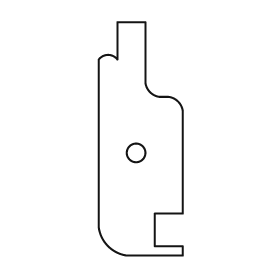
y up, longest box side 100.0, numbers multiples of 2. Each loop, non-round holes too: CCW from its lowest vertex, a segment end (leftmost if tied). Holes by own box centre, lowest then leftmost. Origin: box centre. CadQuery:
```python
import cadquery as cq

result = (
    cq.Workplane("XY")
    .moveTo(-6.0, -50.0)
    .lineTo(18.0, -50.0)
    .lineTo(18.0, -46.0)
    .lineTo(6.0, -46.0)
    .lineTo(6.0, -32.0)
    .lineTo(18.0, -32.0)
    .lineTo(18.0, 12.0)
    .threePointArc((16.0, 16.0), (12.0, 18.0))
    .lineTo(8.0, 18.0)
    .threePointArc((4.0, 20.0), (2.0, 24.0))
    .lineTo(2.0, 50.0)
    .lineTo(-10.0, 50.0)
    .lineTo(-10.0, 34.0)
    .threePointArc((-14.0, 36.0), (-18.0, 34.0))
    .lineTo(-18.0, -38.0)
    .threePointArc((-14.0, -46.0), (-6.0, -50.0))
    .close()
    .moveTo(-2.0, -6.0)
    .circle(4.0)
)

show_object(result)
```